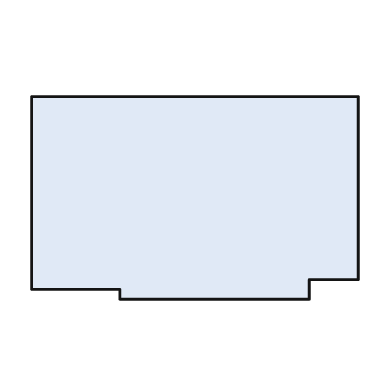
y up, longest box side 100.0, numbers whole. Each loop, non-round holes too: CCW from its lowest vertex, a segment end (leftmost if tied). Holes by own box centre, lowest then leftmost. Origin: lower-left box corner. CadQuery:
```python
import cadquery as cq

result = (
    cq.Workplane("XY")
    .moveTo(27.0, 0.0)
    .lineTo(85.0, 0.0)
    .lineTo(85.0, 6.0)
    .lineTo(100.0, 6.0)
    .lineTo(100.0, 62.0)
    .lineTo(0.0, 62.0)
    .lineTo(0.0, 3.0)
    .lineTo(27.0, 3.0)
    .close()
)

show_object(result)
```